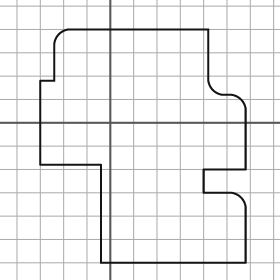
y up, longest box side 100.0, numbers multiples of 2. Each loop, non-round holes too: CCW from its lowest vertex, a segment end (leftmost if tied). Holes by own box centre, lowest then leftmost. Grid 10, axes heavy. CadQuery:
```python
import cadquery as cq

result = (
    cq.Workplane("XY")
    .moveTo(-4.0, -60.0)
    .lineTo(58.0, -60.0)
    .lineTo(58.0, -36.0)
    .threePointArc((56.0, -32.0), (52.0, -30.0))
    .lineTo(40.0, -30.0)
    .lineTo(40.0, -20.0)
    .lineTo(58.0, -20.0)
    .lineTo(58.0, 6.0)
    .threePointArc((56.0, 10.0), (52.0, 12.0))
    .lineTo(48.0, 12.0)
    .threePointArc((44.0, 14.0), (42.0, 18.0))
    .lineTo(42.0, 40.0)
    .lineTo(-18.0, 40.0)
    .threePointArc((-22.0, 38.0), (-24.0, 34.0))
    .lineTo(-24.0, 18.0)
    .lineTo(-30.0, 18.0)
    .lineTo(-30.0, -18.0)
    .lineTo(-4.0, -18.0)
    .close()
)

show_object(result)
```